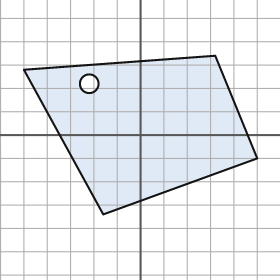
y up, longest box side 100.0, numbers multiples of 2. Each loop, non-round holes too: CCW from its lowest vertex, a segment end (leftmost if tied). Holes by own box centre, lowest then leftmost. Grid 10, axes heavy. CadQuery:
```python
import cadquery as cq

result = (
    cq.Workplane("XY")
    .moveTo(-16.0, -34.0)
    .lineTo(50.0, -10.0)
    .lineTo(32.0, 34.0)
    .lineTo(-50.0, 28.0)
    .close()
    .moveTo(-22.0, 22.0)
    .circle(4.0)
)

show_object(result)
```